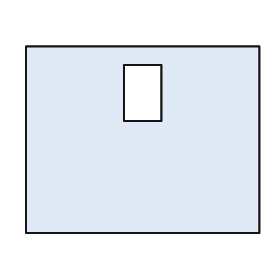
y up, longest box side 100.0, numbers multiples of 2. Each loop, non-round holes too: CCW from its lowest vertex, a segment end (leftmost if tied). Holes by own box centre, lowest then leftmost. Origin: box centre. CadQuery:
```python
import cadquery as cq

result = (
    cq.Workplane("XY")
    .moveTo(-50.0, -40.0)
    .lineTo(50.0, -40.0)
    .lineTo(50.0, 40.0)
    .lineTo(-50.0, 40.0)
    .close()
    .moveTo(-8.0, 8.0)
    .lineTo(8.0, 8.0)
    .lineTo(8.0, 32.0)
    .lineTo(-8.0, 32.0)
    .close()
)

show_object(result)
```